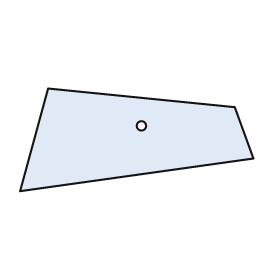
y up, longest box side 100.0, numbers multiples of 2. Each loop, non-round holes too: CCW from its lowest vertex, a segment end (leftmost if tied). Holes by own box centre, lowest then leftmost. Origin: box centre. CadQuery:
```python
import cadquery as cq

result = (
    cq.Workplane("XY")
    .moveTo(-50.0, -22.0)
    .lineTo(50.0, -8.0)
    .lineTo(42.0, 14.0)
    .lineTo(-38.0, 22.0)
    .close()
    .moveTo(2.0, 6.0)
    .circle(2.0)
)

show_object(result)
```